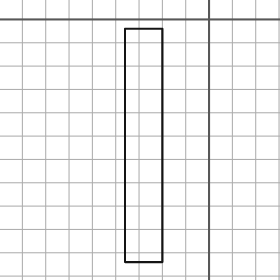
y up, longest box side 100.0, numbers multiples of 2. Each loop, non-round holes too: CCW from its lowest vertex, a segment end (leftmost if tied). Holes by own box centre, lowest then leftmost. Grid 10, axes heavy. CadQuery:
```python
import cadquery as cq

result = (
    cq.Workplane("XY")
    .moveTo(-36.0, -104.0)
    .lineTo(-20.0, -104.0)
    .lineTo(-20.0, -4.0)
    .lineTo(-36.0, -4.0)
    .close()
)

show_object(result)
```